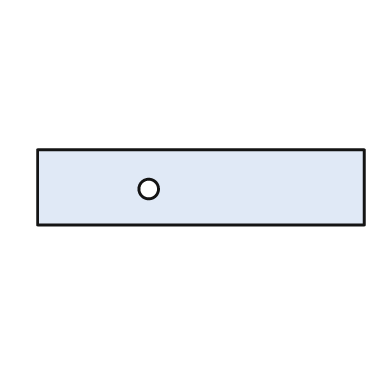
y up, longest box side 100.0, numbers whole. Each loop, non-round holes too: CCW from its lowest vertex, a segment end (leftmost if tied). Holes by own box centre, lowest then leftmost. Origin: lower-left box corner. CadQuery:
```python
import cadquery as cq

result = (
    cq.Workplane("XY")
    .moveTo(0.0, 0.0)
    .lineTo(100.0, 0.0)
    .lineTo(100.0, 23.0)
    .lineTo(0.0, 23.0)
    .close()
    .moveTo(34.0, 11.0)
    .circle(3.0)
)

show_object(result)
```